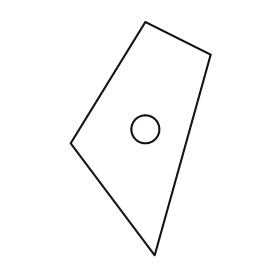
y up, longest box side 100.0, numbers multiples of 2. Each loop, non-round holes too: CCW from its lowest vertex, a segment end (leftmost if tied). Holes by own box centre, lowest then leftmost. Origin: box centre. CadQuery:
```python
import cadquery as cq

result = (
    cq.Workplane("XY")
    .moveTo(6.0, -50.0)
    .lineTo(30.0, 36.0)
    .lineTo(2.0, 50.0)
    .lineTo(-30.0, -2.0)
    .close()
    .moveTo(2.0, 4.0)
    .circle(6.0)
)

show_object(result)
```